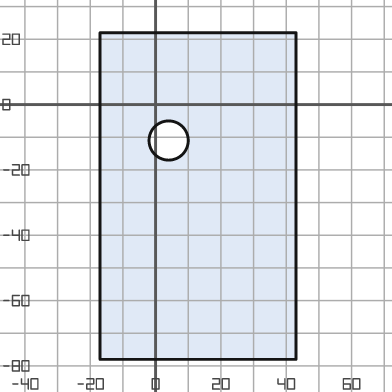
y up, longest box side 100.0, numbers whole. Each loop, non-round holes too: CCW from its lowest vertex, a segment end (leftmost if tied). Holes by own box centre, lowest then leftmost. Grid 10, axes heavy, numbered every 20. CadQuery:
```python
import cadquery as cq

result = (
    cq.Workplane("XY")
    .moveTo(-17.0, -78.0)
    .lineTo(43.0, -78.0)
    .lineTo(43.0, 22.0)
    .lineTo(-17.0, 22.0)
    .close()
    .moveTo(4.0, -11.0)
    .circle(6.0)
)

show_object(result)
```